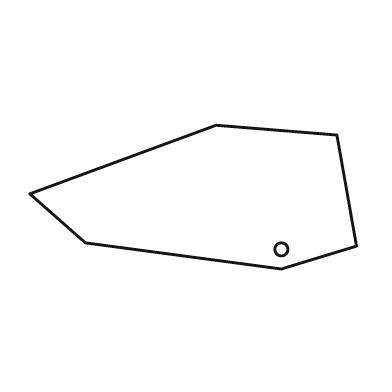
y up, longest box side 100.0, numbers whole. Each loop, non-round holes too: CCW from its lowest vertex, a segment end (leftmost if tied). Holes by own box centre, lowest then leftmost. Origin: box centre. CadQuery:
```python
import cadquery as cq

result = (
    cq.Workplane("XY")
    .moveTo(27.0, -22.0)
    .lineTo(50.0, -15.0)
    .lineTo(44.0, 19.0)
    .lineTo(7.0, 22.0)
    .lineTo(-50.0, 1.0)
    .lineTo(-33.0, -14.0)
    .close()
    .moveTo(27.0, -16.0)
    .circle(2.0)
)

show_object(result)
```